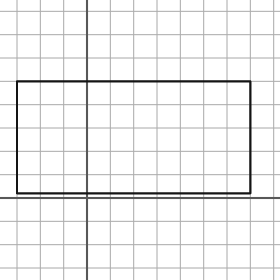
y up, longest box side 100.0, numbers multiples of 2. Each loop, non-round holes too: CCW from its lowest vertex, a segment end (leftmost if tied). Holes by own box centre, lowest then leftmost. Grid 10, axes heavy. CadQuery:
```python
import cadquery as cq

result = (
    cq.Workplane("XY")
    .moveTo(-30.0, 2.0)
    .lineTo(70.0, 2.0)
    .lineTo(70.0, 50.0)
    .lineTo(-30.0, 50.0)
    .close()
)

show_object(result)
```